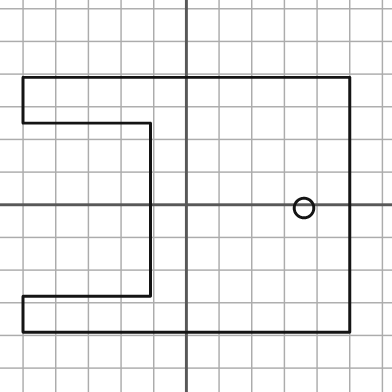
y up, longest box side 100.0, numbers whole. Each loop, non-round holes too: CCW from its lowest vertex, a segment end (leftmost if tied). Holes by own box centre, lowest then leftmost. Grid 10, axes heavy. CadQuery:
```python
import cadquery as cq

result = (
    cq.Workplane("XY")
    .moveTo(-50.0, -39.0)
    .lineTo(50.0, -39.0)
    .lineTo(50.0, 39.0)
    .lineTo(-50.0, 39.0)
    .lineTo(-50.0, 25.0)
    .lineTo(-11.0, 25.0)
    .lineTo(-11.0, -28.0)
    .lineTo(-50.0, -28.0)
    .close()
    .moveTo(36.0, -1.0)
    .circle(3.0)
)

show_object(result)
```